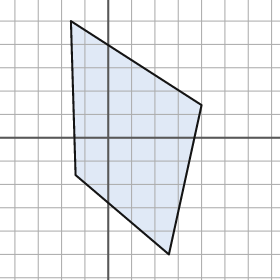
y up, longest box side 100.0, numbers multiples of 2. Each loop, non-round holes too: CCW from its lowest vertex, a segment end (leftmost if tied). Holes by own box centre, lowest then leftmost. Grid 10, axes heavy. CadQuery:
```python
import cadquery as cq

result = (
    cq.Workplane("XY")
    .moveTo(26.0, -50.0)
    .lineTo(40.0, 14.0)
    .lineTo(-16.0, 50.0)
    .lineTo(-14.0, -16.0)
    .close()
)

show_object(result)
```